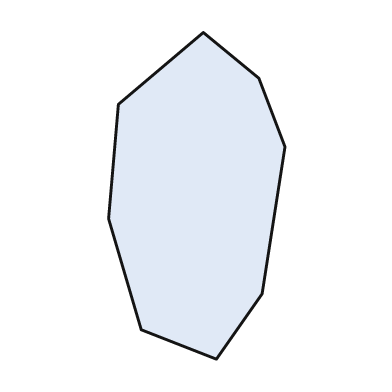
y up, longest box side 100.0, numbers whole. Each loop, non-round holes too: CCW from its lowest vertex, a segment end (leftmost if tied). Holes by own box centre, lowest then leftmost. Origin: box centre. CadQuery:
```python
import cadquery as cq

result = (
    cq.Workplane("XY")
    .moveTo(6.0, -50.0)
    .lineTo(20.0, -30.0)
    .lineTo(27.0, 15.0)
    .lineTo(19.0, 36.0)
    .lineTo(2.0, 50.0)
    .lineTo(-24.0, 28.0)
    .lineTo(-27.0, -7.0)
    .lineTo(-17.0, -41.0)
    .close()
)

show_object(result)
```